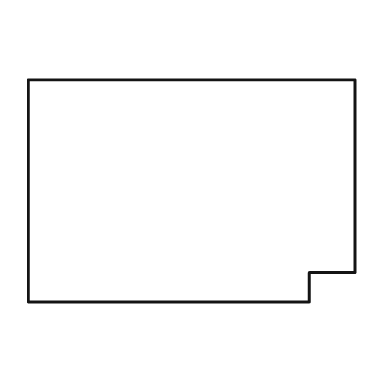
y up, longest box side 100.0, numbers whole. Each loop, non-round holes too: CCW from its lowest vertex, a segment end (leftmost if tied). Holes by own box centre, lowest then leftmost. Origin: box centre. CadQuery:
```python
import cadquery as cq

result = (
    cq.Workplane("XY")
    .moveTo(-50.0, -34.0)
    .lineTo(36.0, -34.0)
    .lineTo(36.0, -25.0)
    .lineTo(50.0, -25.0)
    .lineTo(50.0, 34.0)
    .lineTo(-50.0, 34.0)
    .close()
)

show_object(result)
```